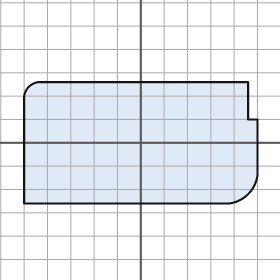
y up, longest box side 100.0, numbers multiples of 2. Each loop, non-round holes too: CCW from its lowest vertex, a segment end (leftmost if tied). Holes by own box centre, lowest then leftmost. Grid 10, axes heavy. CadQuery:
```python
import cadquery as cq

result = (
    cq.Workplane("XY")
    .moveTo(-50.0, -26.0)
    .lineTo(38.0, -26.0)
    .threePointArc((46.0, -22.0), (50.0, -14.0))
    .lineTo(50.0, 10.0)
    .lineTo(46.0, 10.0)
    .lineTo(46.0, 26.0)
    .lineTo(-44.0, 26.0)
    .threePointArc((-48.0, 24.0), (-50.0, 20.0))
    .close()
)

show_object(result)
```